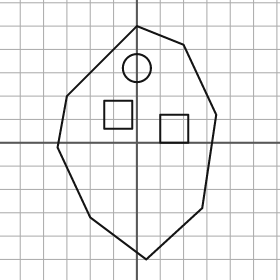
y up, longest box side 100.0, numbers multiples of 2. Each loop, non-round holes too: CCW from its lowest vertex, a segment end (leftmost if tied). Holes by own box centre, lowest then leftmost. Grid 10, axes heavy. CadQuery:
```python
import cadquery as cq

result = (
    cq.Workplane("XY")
    .moveTo(4.0, -50.0)
    .lineTo(28.0, -28.0)
    .lineTo(34.0, 12.0)
    .lineTo(20.0, 42.0)
    .lineTo(0.0, 50.0)
    .lineTo(-30.0, 20.0)
    .lineTo(-34.0, -2.0)
    .lineTo(-20.0, -32.0)
    .close()
    .moveTo(10.0, 0.0)
    .lineTo(22.0, 0.0)
    .lineTo(22.0, 12.0)
    .lineTo(10.0, 12.0)
    .close()
    .moveTo(-14.0, 6.0)
    .lineTo(-2.0, 6.0)
    .lineTo(-2.0, 18.0)
    .lineTo(-14.0, 18.0)
    .close()
    .moveTo(0.0, 32.0)
    .circle(6.0)
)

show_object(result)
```